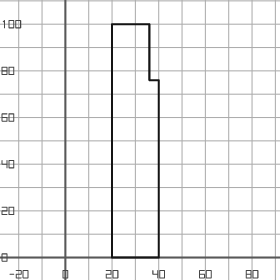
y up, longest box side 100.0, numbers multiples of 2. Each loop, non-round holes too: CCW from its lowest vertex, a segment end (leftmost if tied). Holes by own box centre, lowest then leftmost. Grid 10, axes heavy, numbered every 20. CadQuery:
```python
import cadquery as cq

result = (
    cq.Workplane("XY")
    .moveTo(20.0, 0.0)
    .lineTo(40.0, 0.0)
    .lineTo(40.0, 76.0)
    .lineTo(36.0, 76.0)
    .lineTo(36.0, 100.0)
    .lineTo(20.0, 100.0)
    .close()
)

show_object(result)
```